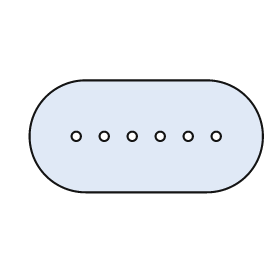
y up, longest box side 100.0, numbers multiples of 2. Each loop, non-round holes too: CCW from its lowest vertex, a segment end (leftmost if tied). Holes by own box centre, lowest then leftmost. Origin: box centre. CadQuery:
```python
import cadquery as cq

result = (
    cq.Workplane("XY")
    .moveTo(-26.0, -24.0)
    .lineTo(26.0, -24.0)
    .threePointArc((50.0, 0.0), (26.0, 24.0))
    .lineTo(-26.0, 24.0)
    .threePointArc((-50.0, 0.0), (-26.0, -24.0))
    .close()
    .moveTo(-30.0, 0.0)
    .circle(2.0)
    .moveTo(-18.0, 0.0)
    .circle(2.0)
    .moveTo(-6.0, 0.0)
    .circle(2.0)
    .moveTo(6.0, 0.0)
    .circle(2.0)
    .moveTo(18.0, 0.0)
    .circle(2.0)
    .moveTo(30.0, 0.0)
    .circle(2.0)
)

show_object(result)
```